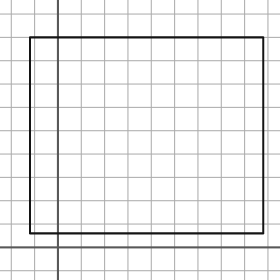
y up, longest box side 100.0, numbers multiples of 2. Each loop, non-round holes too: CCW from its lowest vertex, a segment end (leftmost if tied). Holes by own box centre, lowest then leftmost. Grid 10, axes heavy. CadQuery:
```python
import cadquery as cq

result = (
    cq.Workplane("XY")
    .moveTo(-12.0, 6.0)
    .lineTo(88.0, 6.0)
    .lineTo(88.0, 90.0)
    .lineTo(-12.0, 90.0)
    .close()
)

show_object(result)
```